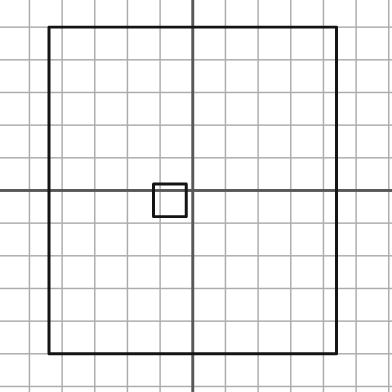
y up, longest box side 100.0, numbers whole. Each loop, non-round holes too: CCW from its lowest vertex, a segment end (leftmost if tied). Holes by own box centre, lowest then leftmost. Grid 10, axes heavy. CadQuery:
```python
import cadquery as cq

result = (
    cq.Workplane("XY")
    .moveTo(-44.0, -50.0)
    .lineTo(44.0, -50.0)
    .lineTo(44.0, 50.0)
    .lineTo(-44.0, 50.0)
    .close()
    .moveTo(-12.0, -8.0)
    .lineTo(-2.0, -8.0)
    .lineTo(-2.0, 2.0)
    .lineTo(-12.0, 2.0)
    .close()
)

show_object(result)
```